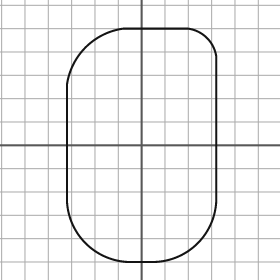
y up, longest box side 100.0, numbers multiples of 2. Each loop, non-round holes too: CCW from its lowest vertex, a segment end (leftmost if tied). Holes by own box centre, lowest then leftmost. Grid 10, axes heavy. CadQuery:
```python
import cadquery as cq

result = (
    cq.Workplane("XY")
    .moveTo(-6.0, -50.0)
    .lineTo(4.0, -50.0)
    .threePointArc((24.0, -42.0), (32.0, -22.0))
    .lineTo(32.0, 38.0)
    .threePointArc((28.0, 46.0), (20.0, 50.0))
    .lineTo(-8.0, 50.0)
    .threePointArc((-24.0, 42.0), (-32.0, 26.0))
    .lineTo(-32.0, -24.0)
    .threePointArc((-24.0, -42.0), (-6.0, -50.0))
    .close()
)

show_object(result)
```